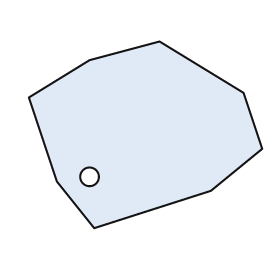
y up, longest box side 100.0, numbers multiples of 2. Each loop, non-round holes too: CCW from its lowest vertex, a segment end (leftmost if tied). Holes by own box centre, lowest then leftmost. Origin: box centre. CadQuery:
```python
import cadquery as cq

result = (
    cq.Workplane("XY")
    .moveTo(-22.0, -40.0)
    .lineTo(28.0, -24.0)
    .lineTo(50.0, -6.0)
    .lineTo(42.0, 18.0)
    .lineTo(6.0, 40.0)
    .lineTo(-24.0, 32.0)
    .lineTo(-50.0, 16.0)
    .lineTo(-38.0, -20.0)
    .close()
    .moveTo(-24.0, -18.0)
    .circle(4.0)
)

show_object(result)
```